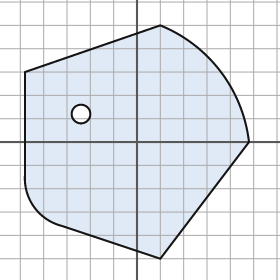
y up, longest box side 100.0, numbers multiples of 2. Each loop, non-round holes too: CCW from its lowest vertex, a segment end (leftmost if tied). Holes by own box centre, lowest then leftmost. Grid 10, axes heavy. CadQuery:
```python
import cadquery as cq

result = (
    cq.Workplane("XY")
    .moveTo(10.0, -50.0)
    .lineTo(48.0, 0.0)
    .threePointArc((36.0, 30.0), (10.0, 50.0))
    .lineTo(-48.0, 30.0)
    .lineTo(-48.0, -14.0)
    .threePointArc((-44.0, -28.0), (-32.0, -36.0))
    .close()
    .moveTo(-24.0, 12.0)
    .circle(4.0)
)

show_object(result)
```